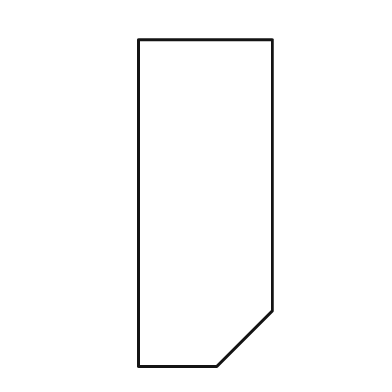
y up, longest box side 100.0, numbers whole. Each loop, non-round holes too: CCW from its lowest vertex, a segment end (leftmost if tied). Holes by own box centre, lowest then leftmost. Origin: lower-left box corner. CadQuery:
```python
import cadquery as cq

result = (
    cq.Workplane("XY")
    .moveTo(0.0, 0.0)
    .lineTo(24.0, 0.0)
    .lineTo(41.0, 17.0)
    .lineTo(41.0, 100.0)
    .lineTo(0.0, 100.0)
    .close()
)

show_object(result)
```